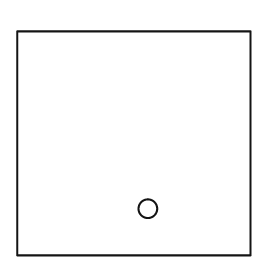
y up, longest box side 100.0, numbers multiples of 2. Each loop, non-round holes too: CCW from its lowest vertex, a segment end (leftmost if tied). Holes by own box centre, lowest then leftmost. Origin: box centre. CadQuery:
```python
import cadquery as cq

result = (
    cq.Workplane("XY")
    .moveTo(-50.0, -48.0)
    .lineTo(50.0, -48.0)
    .lineTo(50.0, 48.0)
    .lineTo(-50.0, 48.0)
    .close()
    .moveTo(6.0, -28.0)
    .circle(4.0)
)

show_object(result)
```